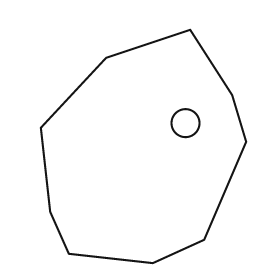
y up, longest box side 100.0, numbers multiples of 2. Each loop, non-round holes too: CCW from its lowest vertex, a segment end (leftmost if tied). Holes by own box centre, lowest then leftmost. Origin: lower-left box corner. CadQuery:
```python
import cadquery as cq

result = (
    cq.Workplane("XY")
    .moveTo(48.0, 0.0)
    .lineTo(70.0, 10.0)
    .lineTo(88.0, 52.0)
    .lineTo(82.0, 72.0)
    .lineTo(64.0, 100.0)
    .lineTo(28.0, 88.0)
    .lineTo(0.0, 58.0)
    .lineTo(4.0, 22.0)
    .lineTo(12.0, 4.0)
    .close()
    .moveTo(62.0, 60.0)
    .circle(6.0)
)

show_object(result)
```